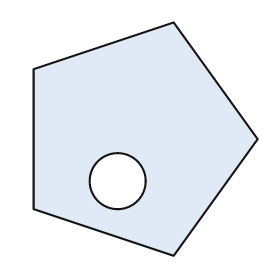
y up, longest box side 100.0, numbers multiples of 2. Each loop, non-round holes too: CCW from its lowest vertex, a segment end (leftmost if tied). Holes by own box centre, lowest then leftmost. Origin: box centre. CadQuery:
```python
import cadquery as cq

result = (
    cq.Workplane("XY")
    .moveTo(12.0, -50.0)
    .lineTo(48.0, 0.0)
    .lineTo(12.0, 50.0)
    .lineTo(-48.0, 30.0)
    .lineTo(-48.0, -30.0)
    .close()
    .moveTo(-12.0, -18.0)
    .circle(12.0)
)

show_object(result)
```